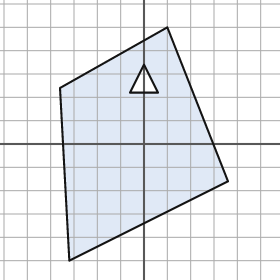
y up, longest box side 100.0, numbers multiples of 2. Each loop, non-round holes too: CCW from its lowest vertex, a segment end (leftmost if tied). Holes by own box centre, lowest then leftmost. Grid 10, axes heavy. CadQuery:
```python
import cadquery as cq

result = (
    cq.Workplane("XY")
    .moveTo(-32.0, -50.0)
    .lineTo(36.0, -16.0)
    .lineTo(10.0, 50.0)
    .lineTo(-36.0, 24.0)
    .close()
    .moveTo(-6.0, 22.0)
    .lineTo(6.0, 22.0)
    .lineTo(0.0, 34.0)
    .close()
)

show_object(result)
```